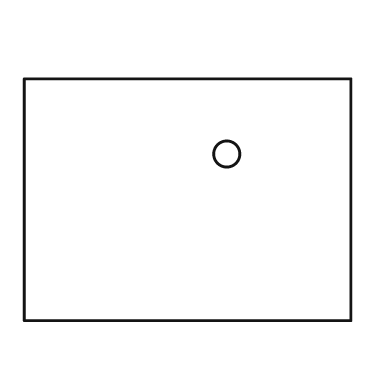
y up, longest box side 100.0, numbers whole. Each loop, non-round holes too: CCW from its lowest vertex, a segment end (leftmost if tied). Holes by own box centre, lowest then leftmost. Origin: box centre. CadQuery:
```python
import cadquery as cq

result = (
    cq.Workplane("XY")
    .moveTo(-50.0, -37.0)
    .lineTo(50.0, -37.0)
    .lineTo(50.0, 37.0)
    .lineTo(-50.0, 37.0)
    .close()
    .moveTo(12.0, 14.0)
    .circle(4.0)
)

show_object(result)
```